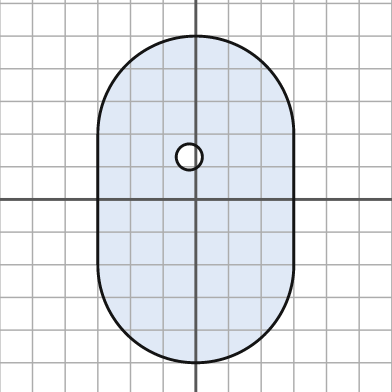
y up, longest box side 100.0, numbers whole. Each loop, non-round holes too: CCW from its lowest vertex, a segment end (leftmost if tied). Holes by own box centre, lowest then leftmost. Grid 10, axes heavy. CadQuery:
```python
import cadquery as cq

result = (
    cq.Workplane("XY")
    .moveTo(-30.0, -20.0)
    .threePointArc((0.0, -50.0), (30.0, -20.0))
    .lineTo(30.0, 20.0)
    .threePointArc((0.0, 50.0), (-30.0, 20.0))
    .close()
    .moveTo(-2.0, 13.0)
    .circle(4.0)
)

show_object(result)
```